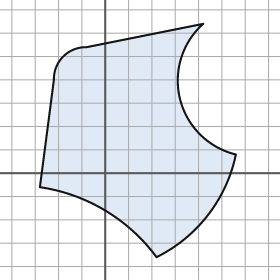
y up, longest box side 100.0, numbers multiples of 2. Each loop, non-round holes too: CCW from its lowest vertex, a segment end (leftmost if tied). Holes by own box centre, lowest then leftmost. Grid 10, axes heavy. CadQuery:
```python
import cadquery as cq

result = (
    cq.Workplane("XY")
    .moveTo(22.0, -36.0)
    .threePointArc((44.0, -18.0), (56.0, 8.0))
    .threePointArc((32.0, 32.0), (42.0, 64.0))
    .lineTo(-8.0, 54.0)
    .threePointArc((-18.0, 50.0), (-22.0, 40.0))
    .lineTo(-28.0, -6.0)
    .threePointArc((0.0, -16.0), (22.0, -36.0))
    .close()
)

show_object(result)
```